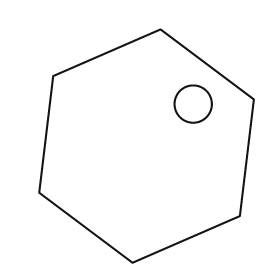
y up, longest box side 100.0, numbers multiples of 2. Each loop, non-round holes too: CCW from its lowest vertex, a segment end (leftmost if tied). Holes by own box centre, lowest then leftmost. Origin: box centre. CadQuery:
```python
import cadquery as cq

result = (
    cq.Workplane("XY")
    .moveTo(-6.0, -50.0)
    .lineTo(40.0, -30.0)
    .lineTo(46.0, 20.0)
    .lineTo(6.0, 50.0)
    .lineTo(-40.0, 30.0)
    .lineTo(-46.0, -20.0)
    .close()
    .moveTo(20.0, 18.0)
    .circle(8.0)
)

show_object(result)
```